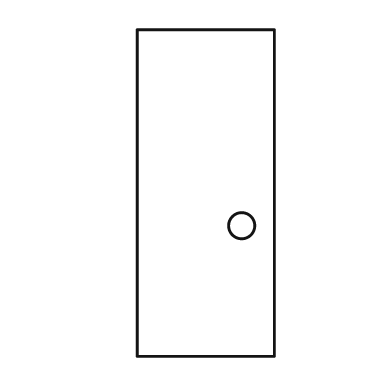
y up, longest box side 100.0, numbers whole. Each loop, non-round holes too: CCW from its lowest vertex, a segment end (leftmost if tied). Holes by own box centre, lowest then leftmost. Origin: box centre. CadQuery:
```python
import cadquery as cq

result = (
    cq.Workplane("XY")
    .moveTo(-21.0, -50.0)
    .lineTo(21.0, -50.0)
    .lineTo(21.0, 50.0)
    .lineTo(-21.0, 50.0)
    .close()
    .moveTo(11.0, -10.0)
    .circle(4.0)
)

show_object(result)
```